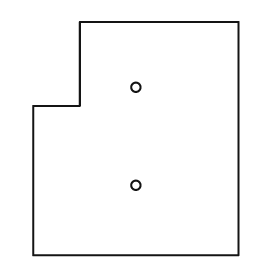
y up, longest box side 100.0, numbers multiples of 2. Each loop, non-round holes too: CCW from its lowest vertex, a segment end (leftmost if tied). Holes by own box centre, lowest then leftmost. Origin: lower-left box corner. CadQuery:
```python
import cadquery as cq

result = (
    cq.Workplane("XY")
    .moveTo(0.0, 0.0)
    .lineTo(88.0, 0.0)
    .lineTo(88.0, 100.0)
    .lineTo(20.0, 100.0)
    .lineTo(20.0, 64.0)
    .lineTo(0.0, 64.0)
    .close()
    .moveTo(44.0, 30.0)
    .circle(2.0)
    .moveTo(44.0, 72.0)
    .circle(2.0)
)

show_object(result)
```